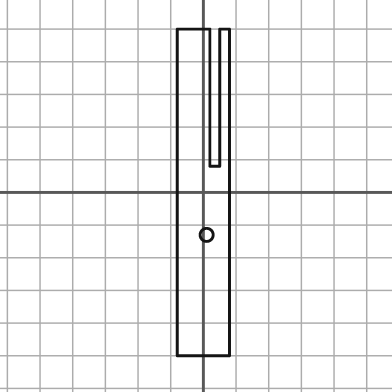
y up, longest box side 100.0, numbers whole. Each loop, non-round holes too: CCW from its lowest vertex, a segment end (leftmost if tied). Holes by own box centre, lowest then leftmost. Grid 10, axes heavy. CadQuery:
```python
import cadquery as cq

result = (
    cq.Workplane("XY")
    .moveTo(-8.0, -50.0)
    .lineTo(8.0, -50.0)
    .lineTo(8.0, 50.0)
    .lineTo(5.0, 50.0)
    .lineTo(5.0, 8.0)
    .lineTo(2.0, 8.0)
    .lineTo(2.0, 50.0)
    .lineTo(-8.0, 50.0)
    .close()
    .moveTo(1.0, -13.0)
    .circle(2.0)
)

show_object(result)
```